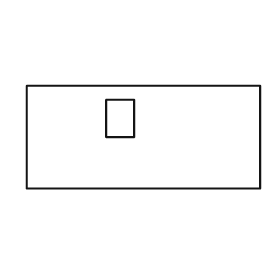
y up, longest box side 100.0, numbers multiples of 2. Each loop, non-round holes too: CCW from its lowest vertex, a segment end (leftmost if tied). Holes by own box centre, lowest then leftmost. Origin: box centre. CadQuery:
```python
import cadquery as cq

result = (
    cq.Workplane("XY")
    .moveTo(-50.0, -22.0)
    .lineTo(50.0, -22.0)
    .lineTo(50.0, 22.0)
    .lineTo(-50.0, 22.0)
    .close()
    .moveTo(-16.0, 0.0)
    .lineTo(-4.0, 0.0)
    .lineTo(-4.0, 16.0)
    .lineTo(-16.0, 16.0)
    .close()
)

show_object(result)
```